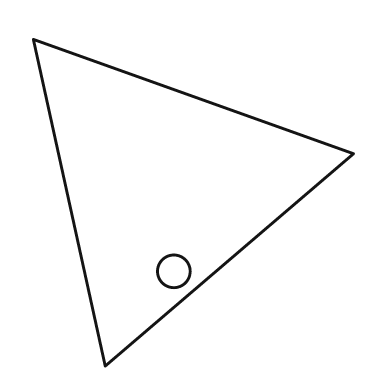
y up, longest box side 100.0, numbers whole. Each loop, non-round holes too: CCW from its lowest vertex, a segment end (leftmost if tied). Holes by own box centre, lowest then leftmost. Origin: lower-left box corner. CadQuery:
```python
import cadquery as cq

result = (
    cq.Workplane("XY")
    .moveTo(22.0, 0.0)
    .lineTo(98.0, 65.0)
    .lineTo(0.0, 100.0)
    .close()
    .moveTo(43.0, 29.0)
    .circle(5.0)
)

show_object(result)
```